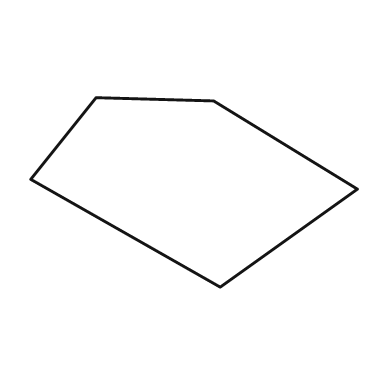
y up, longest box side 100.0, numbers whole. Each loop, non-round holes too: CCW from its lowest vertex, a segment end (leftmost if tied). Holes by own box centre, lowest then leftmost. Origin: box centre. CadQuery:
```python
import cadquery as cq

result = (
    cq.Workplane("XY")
    .moveTo(8.0, -29.0)
    .lineTo(50.0, 1.0)
    .lineTo(6.0, 28.0)
    .lineTo(-30.0, 29.0)
    .lineTo(-50.0, 4.0)
    .close()
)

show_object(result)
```